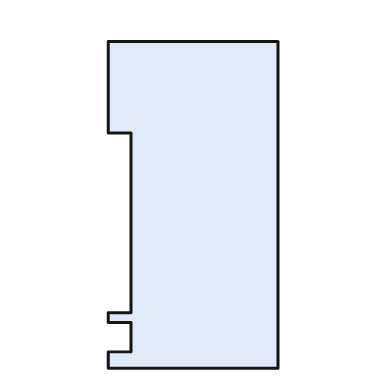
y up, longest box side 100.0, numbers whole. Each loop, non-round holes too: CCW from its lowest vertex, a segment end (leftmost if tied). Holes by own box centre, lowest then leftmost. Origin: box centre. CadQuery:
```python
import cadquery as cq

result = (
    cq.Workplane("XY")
    .moveTo(-26.0, -50.0)
    .lineTo(26.0, -50.0)
    .lineTo(26.0, 50.0)
    .lineTo(-26.0, 50.0)
    .lineTo(-26.0, 22.0)
    .lineTo(-19.0, 22.0)
    .lineTo(-19.0, -33.0)
    .lineTo(-26.0, -33.0)
    .lineTo(-26.0, -36.0)
    .lineTo(-19.0, -36.0)
    .lineTo(-19.0, -45.0)
    .lineTo(-26.0, -45.0)
    .close()
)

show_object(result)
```